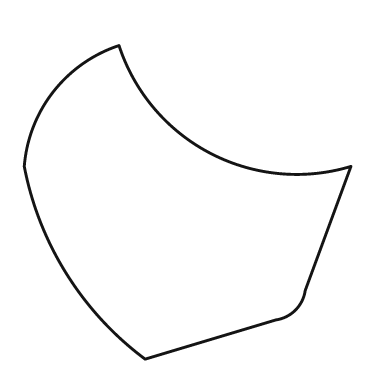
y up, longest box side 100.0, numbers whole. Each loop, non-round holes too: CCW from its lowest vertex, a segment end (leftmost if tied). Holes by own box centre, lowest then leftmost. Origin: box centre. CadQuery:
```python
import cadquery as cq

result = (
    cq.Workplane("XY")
    .moveTo(-13.0, -48.0)
    .lineTo(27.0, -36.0)
    .threePointArc((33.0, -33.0), (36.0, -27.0))
    .lineTo(50.0, 11.0)
    .threePointArc((7.0, 15.0), (-21.0, 48.0))
    .threePointArc((-41.0, 34.0), (-50.0, 11.0))
    .threePointArc((-37.0, -22.0), (-13.0, -48.0))
    .close()
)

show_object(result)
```